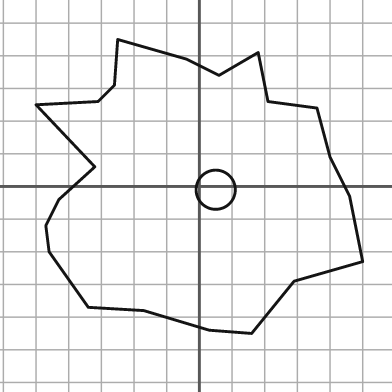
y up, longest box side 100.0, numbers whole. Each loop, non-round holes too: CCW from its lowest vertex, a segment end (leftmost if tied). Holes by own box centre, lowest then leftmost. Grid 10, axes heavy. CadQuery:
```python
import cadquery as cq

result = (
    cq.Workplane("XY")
    .moveTo(16.0, -45.0)
    .lineTo(29.0, -29.0)
    .lineTo(50.0, -23.0)
    .lineTo(46.0, -3.0)
    .lineTo(40.0, 9.0)
    .lineTo(36.0, 24.0)
    .lineTo(21.0, 26.0)
    .lineTo(18.0, 41.0)
    .lineTo(6.0, 34.0)
    .lineTo(-4.0, 39.0)
    .lineTo(-25.0, 45.0)
    .lineTo(-26.0, 31.0)
    .lineTo(-31.0, 26.0)
    .lineTo(-50.0, 25.0)
    .lineTo(-32.0, 6.0)
    .lineTo(-43.0, -4.0)
    .lineTo(-47.0, -12.0)
    .lineTo(-46.0, -20.0)
    .lineTo(-34.0, -37.0)
    .lineTo(-17.0, -38.0)
    .lineTo(3.0, -44.0)
    .close()
    .moveTo(5.0, -1.0)
    .circle(6.0)
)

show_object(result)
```